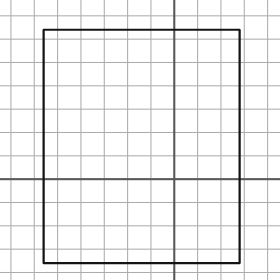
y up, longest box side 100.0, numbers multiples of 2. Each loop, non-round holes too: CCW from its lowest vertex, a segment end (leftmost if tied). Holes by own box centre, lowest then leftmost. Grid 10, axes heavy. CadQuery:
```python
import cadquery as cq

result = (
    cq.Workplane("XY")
    .moveTo(-56.0, -36.0)
    .lineTo(28.0, -36.0)
    .lineTo(28.0, 64.0)
    .lineTo(-56.0, 64.0)
    .close()
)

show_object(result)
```